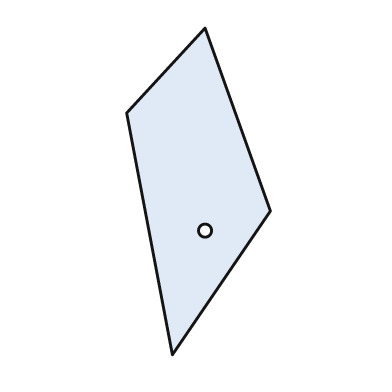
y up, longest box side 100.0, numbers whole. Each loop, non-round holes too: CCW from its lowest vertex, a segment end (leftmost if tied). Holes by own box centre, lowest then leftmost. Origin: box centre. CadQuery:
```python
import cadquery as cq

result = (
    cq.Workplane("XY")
    .moveTo(-8.0, -50.0)
    .lineTo(22.0, -6.0)
    .lineTo(2.0, 50.0)
    .lineTo(-22.0, 24.0)
    .close()
    .moveTo(2.0, -12.0)
    .circle(2.0)
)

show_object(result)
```